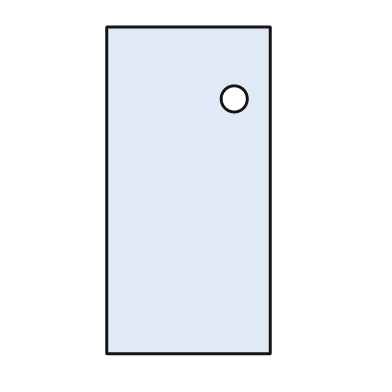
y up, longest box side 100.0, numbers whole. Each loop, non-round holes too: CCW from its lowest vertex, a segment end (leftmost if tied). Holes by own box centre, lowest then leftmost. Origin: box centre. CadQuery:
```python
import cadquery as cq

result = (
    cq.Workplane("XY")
    .moveTo(-25.0, -50.0)
    .lineTo(25.0, -50.0)
    .lineTo(25.0, 50.0)
    .lineTo(-25.0, 50.0)
    .close()
    .moveTo(14.0, 28.0)
    .circle(4.0)
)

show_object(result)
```